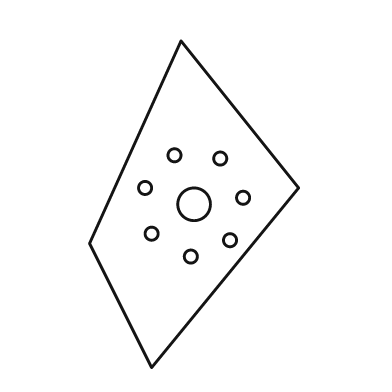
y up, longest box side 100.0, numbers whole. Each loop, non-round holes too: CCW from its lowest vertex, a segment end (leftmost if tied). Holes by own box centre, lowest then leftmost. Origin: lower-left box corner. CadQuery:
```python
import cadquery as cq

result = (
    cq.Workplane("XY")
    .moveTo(19.0, 0.0)
    .lineTo(64.0, 55.0)
    .lineTo(28.0, 100.0)
    .lineTo(0.0, 38.0)
    .close()
    .moveTo(31.0, 34.0)
    .circle(2.0)
    .moveTo(43.0, 39.0)
    .circle(2.0)
    .moveTo(19.0, 41.0)
    .circle(2.0)
    .moveTo(32.0, 50.0)
    .circle(5.0)
    .moveTo(47.0, 52.0)
    .circle(2.0)
    .moveTo(17.0, 55.0)
    .circle(2.0)
    .moveTo(40.0, 64.0)
    .circle(2.0)
    .moveTo(26.0, 65.0)
    .circle(2.0)
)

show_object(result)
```